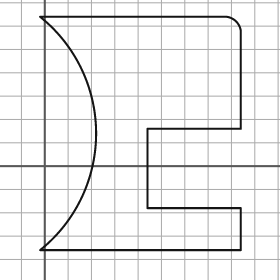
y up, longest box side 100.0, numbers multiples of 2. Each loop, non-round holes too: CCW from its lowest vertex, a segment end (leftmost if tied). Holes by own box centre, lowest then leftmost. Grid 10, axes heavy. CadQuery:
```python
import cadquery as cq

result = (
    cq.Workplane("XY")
    .moveTo(-2.0, -36.0)
    .lineTo(84.0, -36.0)
    .lineTo(84.0, -18.0)
    .lineTo(44.0, -18.0)
    .lineTo(44.0, 16.0)
    .lineTo(84.0, 16.0)
    .lineTo(84.0, 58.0)
    .threePointArc((82.0, 62.0), (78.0, 64.0))
    .lineTo(-2.0, 64.0)
    .threePointArc((22.0, 14.0), (-2.0, -36.0))
    .close()
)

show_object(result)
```